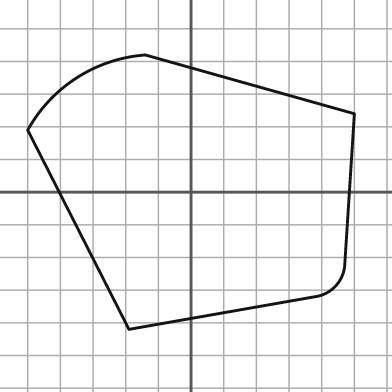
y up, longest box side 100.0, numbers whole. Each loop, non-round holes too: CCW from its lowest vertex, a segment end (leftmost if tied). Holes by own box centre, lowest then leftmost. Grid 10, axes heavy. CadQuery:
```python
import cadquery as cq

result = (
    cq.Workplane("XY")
    .moveTo(-19.0, -42.0)
    .lineTo(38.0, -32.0)
    .threePointArc((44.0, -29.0), (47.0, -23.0))
    .lineTo(50.0, 24.0)
    .lineTo(-14.0, 42.0)
    .threePointArc((-35.0, 35.0), (-50.0, 19.0))
    .close()
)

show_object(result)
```